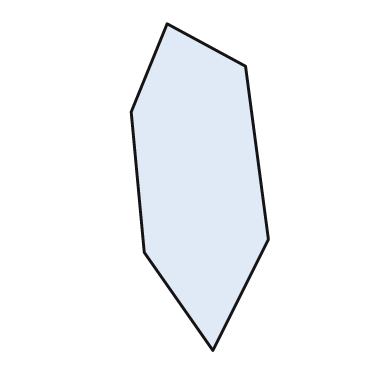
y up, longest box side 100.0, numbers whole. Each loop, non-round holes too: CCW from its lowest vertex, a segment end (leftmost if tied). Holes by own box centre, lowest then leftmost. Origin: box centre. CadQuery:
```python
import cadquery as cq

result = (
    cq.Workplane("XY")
    .moveTo(4.0, -50.0)
    .lineTo(21.0, -16.0)
    .lineTo(14.0, 37.0)
    .lineTo(-10.0, 50.0)
    .lineTo(-21.0, 23.0)
    .lineTo(-17.0, -20.0)
    .close()
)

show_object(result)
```